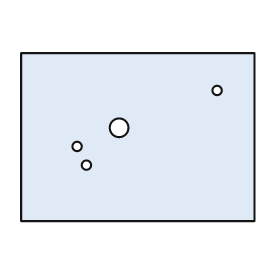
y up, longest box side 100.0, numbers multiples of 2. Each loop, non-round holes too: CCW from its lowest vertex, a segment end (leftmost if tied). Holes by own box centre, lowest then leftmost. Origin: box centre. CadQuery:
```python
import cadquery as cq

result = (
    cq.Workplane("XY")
    .moveTo(-50.0, -36.0)
    .lineTo(50.0, -36.0)
    .lineTo(50.0, 36.0)
    .lineTo(-50.0, 36.0)
    .close()
    .moveTo(-22.0, -12.0)
    .circle(2.0)
    .moveTo(-26.0, -4.0)
    .circle(2.0)
    .moveTo(-8.0, 4.0)
    .circle(4.0)
    .moveTo(34.0, 20.0)
    .circle(2.0)
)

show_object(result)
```